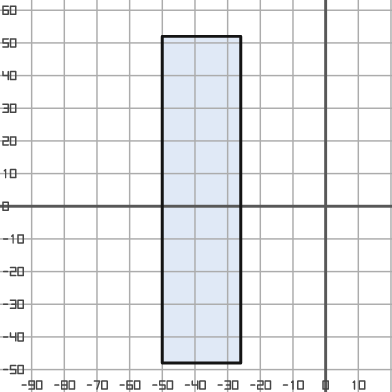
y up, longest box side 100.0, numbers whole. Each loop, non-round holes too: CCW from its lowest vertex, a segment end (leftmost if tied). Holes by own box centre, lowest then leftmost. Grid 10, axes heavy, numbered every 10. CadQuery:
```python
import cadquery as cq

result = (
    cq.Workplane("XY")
    .moveTo(-50.0, -48.0)
    .lineTo(-26.0, -48.0)
    .lineTo(-26.0, 52.0)
    .lineTo(-50.0, 52.0)
    .close()
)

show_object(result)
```